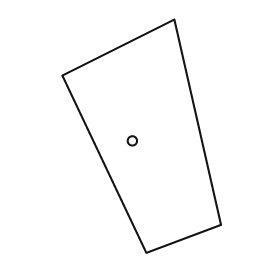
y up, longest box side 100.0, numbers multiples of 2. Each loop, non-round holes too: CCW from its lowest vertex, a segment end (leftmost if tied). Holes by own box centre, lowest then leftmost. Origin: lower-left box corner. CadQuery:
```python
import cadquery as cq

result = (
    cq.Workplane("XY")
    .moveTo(36.0, 0.0)
    .lineTo(68.0, 12.0)
    .lineTo(48.0, 100.0)
    .lineTo(0.0, 76.0)
    .close()
    .moveTo(30.0, 48.0)
    .circle(2.0)
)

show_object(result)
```